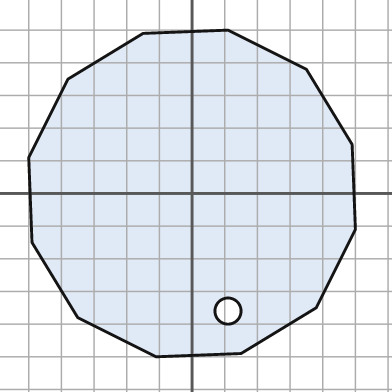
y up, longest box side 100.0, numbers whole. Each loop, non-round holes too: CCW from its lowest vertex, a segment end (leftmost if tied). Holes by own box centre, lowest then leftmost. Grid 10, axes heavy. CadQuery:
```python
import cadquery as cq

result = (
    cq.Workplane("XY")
    .moveTo(-11.0, -50.0)
    .lineTo(15.0, -49.0)
    .lineTo(38.0, -35.0)
    .lineTo(50.0, -11.0)
    .lineTo(49.0, 15.0)
    .lineTo(35.0, 38.0)
    .lineTo(11.0, 50.0)
    .lineTo(-15.0, 49.0)
    .lineTo(-38.0, 35.0)
    .lineTo(-50.0, 11.0)
    .lineTo(-49.0, -15.0)
    .lineTo(-35.0, -38.0)
    .close()
    .moveTo(11.0, -36.0)
    .circle(4.0)
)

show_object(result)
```